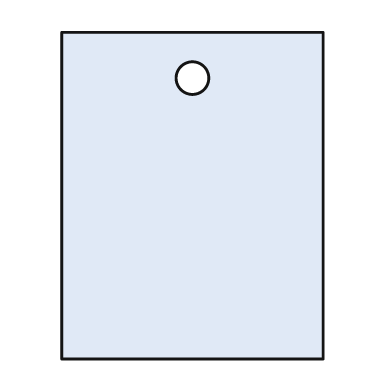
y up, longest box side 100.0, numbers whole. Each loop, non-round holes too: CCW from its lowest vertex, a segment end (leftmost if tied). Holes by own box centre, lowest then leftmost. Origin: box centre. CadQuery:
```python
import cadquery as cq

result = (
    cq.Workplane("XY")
    .moveTo(-40.0, -50.0)
    .lineTo(40.0, -50.0)
    .lineTo(40.0, 50.0)
    .lineTo(-40.0, 50.0)
    .close()
    .moveTo(0.0, 36.0)
    .circle(5.0)
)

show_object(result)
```